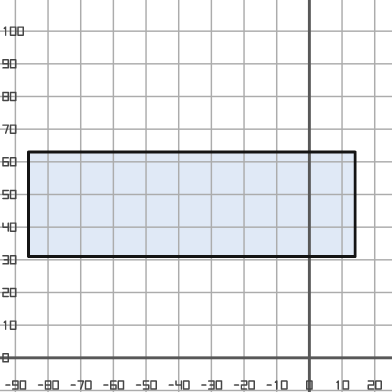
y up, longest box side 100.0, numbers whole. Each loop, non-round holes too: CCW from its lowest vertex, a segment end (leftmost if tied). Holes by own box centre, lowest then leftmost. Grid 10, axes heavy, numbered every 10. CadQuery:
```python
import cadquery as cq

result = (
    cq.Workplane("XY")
    .moveTo(-86.0, 31.0)
    .lineTo(14.0, 31.0)
    .lineTo(14.0, 63.0)
    .lineTo(-86.0, 63.0)
    .close()
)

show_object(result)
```